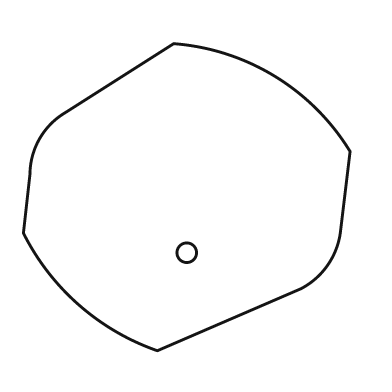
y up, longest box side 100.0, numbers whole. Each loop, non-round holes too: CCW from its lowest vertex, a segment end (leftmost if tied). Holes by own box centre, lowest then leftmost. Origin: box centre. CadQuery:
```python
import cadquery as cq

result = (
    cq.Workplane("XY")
    .moveTo(-9.0, -47.0)
    .lineTo(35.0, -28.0)
    .threePointArc((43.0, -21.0), (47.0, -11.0))
    .lineTo(50.0, 14.0)
    .threePointArc((27.0, 37.0), (-4.0, 47.0))
    .lineTo(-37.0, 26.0)
    .threePointArc((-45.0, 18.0), (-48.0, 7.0))
    .lineTo(-50.0, -11.0)
    .threePointArc((-33.0, -33.0), (-9.0, -47.0))
    .close()
    .moveTo(0.0, -17.0)
    .circle(3.0)
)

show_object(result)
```